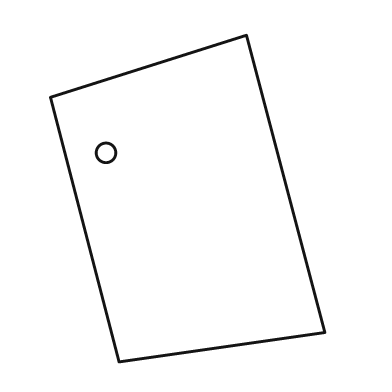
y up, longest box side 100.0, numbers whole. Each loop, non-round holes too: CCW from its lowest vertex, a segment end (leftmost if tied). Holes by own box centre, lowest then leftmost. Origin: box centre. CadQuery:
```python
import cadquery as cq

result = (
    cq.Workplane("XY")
    .moveTo(-21.0, -50.0)
    .lineTo(42.0, -41.0)
    .lineTo(18.0, 50.0)
    .lineTo(-42.0, 31.0)
    .close()
    .moveTo(-25.0, 14.0)
    .circle(3.0)
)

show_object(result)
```